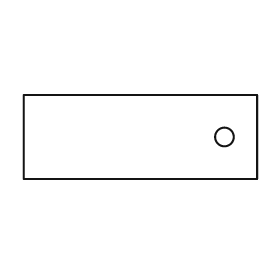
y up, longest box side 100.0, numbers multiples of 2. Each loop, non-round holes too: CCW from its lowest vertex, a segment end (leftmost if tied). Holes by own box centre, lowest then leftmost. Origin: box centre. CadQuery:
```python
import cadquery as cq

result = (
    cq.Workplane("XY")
    .moveTo(-50.0, -18.0)
    .lineTo(50.0, -18.0)
    .lineTo(50.0, 18.0)
    .lineTo(-50.0, 18.0)
    .close()
    .moveTo(36.0, 0.0)
    .circle(4.0)
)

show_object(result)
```